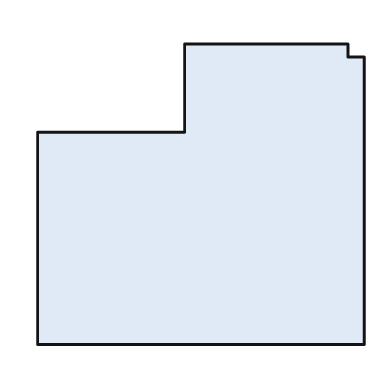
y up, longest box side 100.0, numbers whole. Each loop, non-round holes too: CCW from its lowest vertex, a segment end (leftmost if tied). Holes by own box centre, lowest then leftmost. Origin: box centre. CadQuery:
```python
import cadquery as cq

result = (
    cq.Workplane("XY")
    .moveTo(-50.0, -46.0)
    .lineTo(50.0, -46.0)
    .lineTo(50.0, 42.0)
    .lineTo(45.0, 42.0)
    .lineTo(45.0, 46.0)
    .lineTo(-5.0, 46.0)
    .lineTo(-5.0, 19.0)
    .lineTo(-50.0, 19.0)
    .close()
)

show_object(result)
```